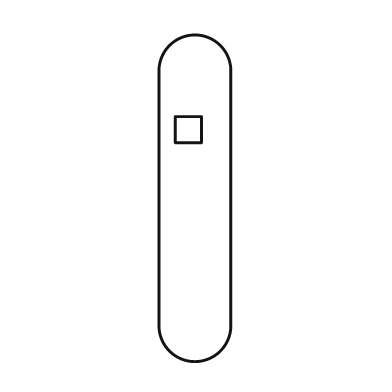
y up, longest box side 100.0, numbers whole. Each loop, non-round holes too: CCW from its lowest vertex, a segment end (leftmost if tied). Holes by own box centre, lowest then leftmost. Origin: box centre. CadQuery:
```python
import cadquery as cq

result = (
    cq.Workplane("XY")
    .moveTo(-11.0, -39.0)
    .threePointArc((0.0, -50.0), (11.0, -39.0))
    .lineTo(11.0, 39.0)
    .threePointArc((0.0, 50.0), (-11.0, 39.0))
    .close()
    .moveTo(-6.0, 17.0)
    .lineTo(2.0, 17.0)
    .lineTo(2.0, 25.0)
    .lineTo(-6.0, 25.0)
    .close()
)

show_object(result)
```